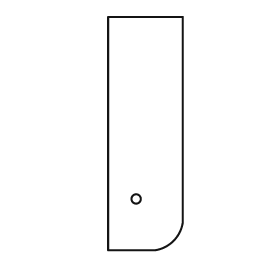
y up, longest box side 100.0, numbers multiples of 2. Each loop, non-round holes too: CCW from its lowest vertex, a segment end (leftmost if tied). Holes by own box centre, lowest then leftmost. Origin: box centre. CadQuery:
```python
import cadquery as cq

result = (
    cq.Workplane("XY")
    .moveTo(-16.0, -50.0)
    .lineTo(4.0, -50.0)
    .threePointArc((12.0, -46.0), (16.0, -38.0))
    .lineTo(16.0, 50.0)
    .lineTo(-16.0, 50.0)
    .close()
    .moveTo(-4.0, -28.0)
    .circle(2.0)
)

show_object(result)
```